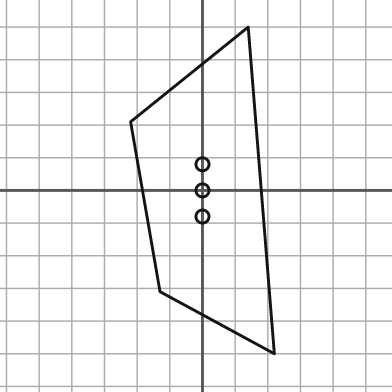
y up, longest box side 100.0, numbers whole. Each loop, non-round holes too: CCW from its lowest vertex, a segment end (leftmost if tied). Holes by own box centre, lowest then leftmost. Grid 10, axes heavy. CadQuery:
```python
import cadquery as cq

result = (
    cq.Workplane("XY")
    .moveTo(22.0, -50.0)
    .lineTo(14.0, 50.0)
    .lineTo(-22.0, 21.0)
    .lineTo(-13.0, -31.0)
    .close()
    .moveTo(0.0, -8.0)
    .circle(2.0)
    .moveTo(0.0, 0.0)
    .circle(2.0)
    .moveTo(0.0, 8.0)
    .circle(2.0)
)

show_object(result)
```